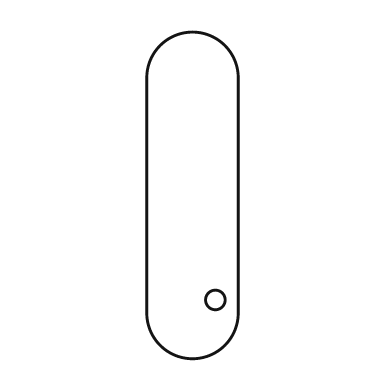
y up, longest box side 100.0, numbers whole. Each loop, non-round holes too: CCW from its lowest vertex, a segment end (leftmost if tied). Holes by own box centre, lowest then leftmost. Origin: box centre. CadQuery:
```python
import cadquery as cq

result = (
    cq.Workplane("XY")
    .moveTo(-14.0, -36.0)
    .threePointArc((0.0, -50.0), (14.0, -36.0))
    .lineTo(14.0, 36.0)
    .threePointArc((0.0, 50.0), (-14.0, 36.0))
    .close()
    .moveTo(7.0, -32.0)
    .circle(3.0)
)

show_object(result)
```